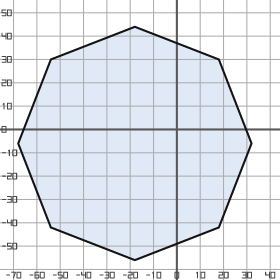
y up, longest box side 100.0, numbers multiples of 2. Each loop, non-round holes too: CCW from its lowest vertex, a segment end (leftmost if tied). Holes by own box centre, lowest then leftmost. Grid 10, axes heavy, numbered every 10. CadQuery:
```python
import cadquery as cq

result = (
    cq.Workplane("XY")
    .moveTo(-18.0, -56.0)
    .lineTo(18.0, -42.0)
    .lineTo(32.0, -6.0)
    .lineTo(18.0, 30.0)
    .lineTo(-18.0, 44.0)
    .lineTo(-54.0, 30.0)
    .lineTo(-68.0, -6.0)
    .lineTo(-54.0, -42.0)
    .close()
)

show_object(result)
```